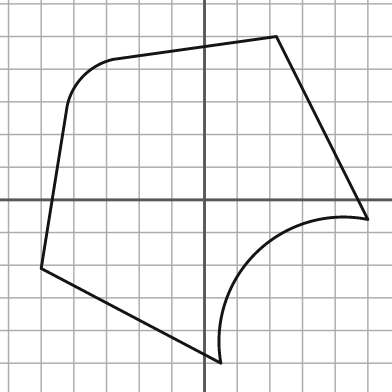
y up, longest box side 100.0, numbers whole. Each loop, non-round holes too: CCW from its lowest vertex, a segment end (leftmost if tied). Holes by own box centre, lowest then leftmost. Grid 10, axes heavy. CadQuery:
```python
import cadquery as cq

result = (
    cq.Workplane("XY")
    .moveTo(5.0, -50.0)
    .threePointArc((16.0, -16.0), (50.0, -6.0))
    .lineTo(22.0, 50.0)
    .lineTo(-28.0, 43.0)
    .threePointArc((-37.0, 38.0), (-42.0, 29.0))
    .lineTo(-50.0, -21.0)
    .close()
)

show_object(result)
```